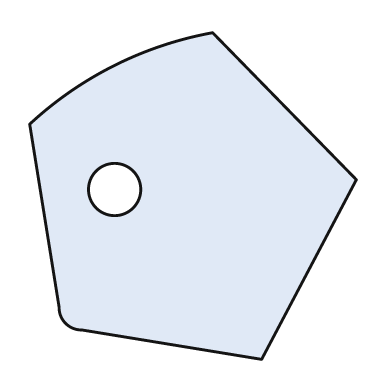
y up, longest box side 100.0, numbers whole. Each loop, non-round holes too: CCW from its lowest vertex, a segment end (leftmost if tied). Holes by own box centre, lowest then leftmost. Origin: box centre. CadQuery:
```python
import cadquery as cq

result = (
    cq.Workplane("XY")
    .moveTo(21.0, -50.0)
    .lineTo(50.0, 5.0)
    .lineTo(6.0, 50.0)
    .threePointArc((-24.0, 40.0), (-50.0, 22.0))
    .lineTo(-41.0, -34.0)
    .threePointArc((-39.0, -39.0), (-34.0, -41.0))
    .close()
    .moveTo(-24.0, 2.0)
    .circle(8.0)
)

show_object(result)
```